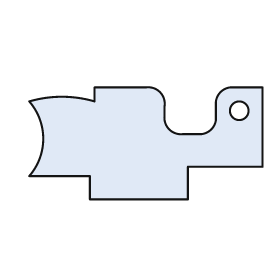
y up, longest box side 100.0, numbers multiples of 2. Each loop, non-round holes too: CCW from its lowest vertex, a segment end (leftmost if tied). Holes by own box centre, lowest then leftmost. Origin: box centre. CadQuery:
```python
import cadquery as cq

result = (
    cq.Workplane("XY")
    .moveTo(-24.0, -24.0)
    .lineTo(18.0, -24.0)
    .lineTo(18.0, -10.0)
    .lineTo(50.0, -10.0)
    .lineTo(50.0, 24.0)
    .lineTo(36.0, 24.0)
    .threePointArc((32.0, 22.0), (30.0, 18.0))
    .lineTo(30.0, 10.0)
    .threePointArc((28.0, 6.0), (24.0, 4.0))
    .lineTo(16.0, 4.0)
    .threePointArc((10.0, 6.0), (8.0, 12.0))
    .lineTo(8.0, 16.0)
    .threePointArc((6.0, 22.0), (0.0, 24.0))
    .lineTo(-22.0, 24.0)
    .lineTo(-22.0, 18.0)
    .threePointArc((-36.0, 20.0), (-50.0, 18.0))
    .threePointArc((-44.0, 2.0), (-50.0, -14.0))
    .lineTo(-24.0, -14.0)
    .close()
    .moveTo(40.0, 14.0)
    .circle(4.0)
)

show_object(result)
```